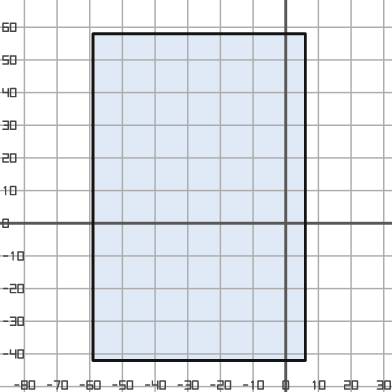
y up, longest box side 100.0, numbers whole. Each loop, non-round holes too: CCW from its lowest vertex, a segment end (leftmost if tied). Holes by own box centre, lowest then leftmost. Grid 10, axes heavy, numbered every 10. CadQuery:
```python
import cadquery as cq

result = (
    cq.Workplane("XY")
    .moveTo(-59.0, -42.0)
    .lineTo(6.0, -42.0)
    .lineTo(6.0, 58.0)
    .lineTo(-59.0, 58.0)
    .close()
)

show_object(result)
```